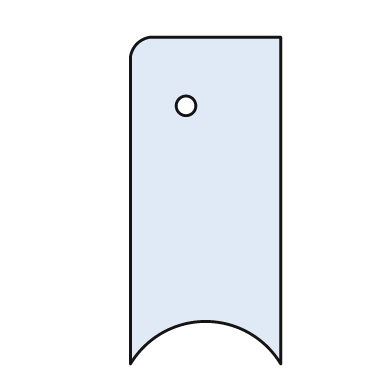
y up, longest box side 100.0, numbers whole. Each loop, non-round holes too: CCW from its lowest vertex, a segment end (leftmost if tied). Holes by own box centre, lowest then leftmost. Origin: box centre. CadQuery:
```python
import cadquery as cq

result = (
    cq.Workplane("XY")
    .moveTo(-23.0, -50.0)
    .threePointArc((0.0, -37.0), (23.0, -50.0))
    .lineTo(23.0, 50.0)
    .lineTo(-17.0, 50.0)
    .threePointArc((-21.0, 48.0), (-23.0, 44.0))
    .close()
    .moveTo(-6.0, 29.0)
    .circle(3.0)
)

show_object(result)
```